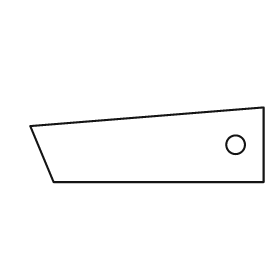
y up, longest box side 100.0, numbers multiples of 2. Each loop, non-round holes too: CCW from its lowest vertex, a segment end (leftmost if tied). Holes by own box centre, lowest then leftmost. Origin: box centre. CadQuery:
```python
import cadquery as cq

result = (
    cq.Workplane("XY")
    .moveTo(-40.0, -16.0)
    .lineTo(50.0, -16.0)
    .lineTo(50.0, 16.0)
    .lineTo(-50.0, 8.0)
    .close()
    .moveTo(38.0, 0.0)
    .circle(4.0)
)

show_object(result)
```